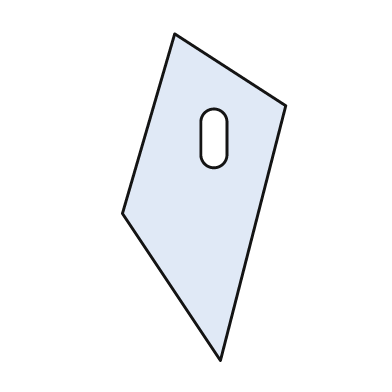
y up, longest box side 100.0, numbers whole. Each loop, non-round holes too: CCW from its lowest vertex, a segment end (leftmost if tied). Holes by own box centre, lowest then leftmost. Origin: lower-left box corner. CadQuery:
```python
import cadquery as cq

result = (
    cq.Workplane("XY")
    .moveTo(30.0, 0.0)
    .lineTo(50.0, 78.0)
    .lineTo(16.0, 100.0)
    .lineTo(0.0, 45.0)
    .close()
    .moveTo(24.0, 63.0)
    .threePointArc((28.0, 59.0), (32.0, 63.0))
    .lineTo(32.0, 73.0)
    .threePointArc((28.0, 77.0), (24.0, 73.0))
    .close()
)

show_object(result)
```